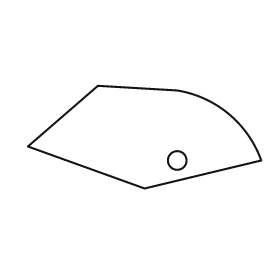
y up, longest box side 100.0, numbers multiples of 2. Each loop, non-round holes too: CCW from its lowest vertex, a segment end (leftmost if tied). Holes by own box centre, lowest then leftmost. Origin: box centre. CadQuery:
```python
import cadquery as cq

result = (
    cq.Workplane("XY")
    .moveTo(0.0, -22.0)
    .lineTo(50.0, -10.0)
    .threePointArc((36.0, 10.0), (14.0, 20.0))
    .lineTo(-20.0, 22.0)
    .lineTo(-50.0, -4.0)
    .close()
    .moveTo(14.0, -10.0)
    .circle(4.0)
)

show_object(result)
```